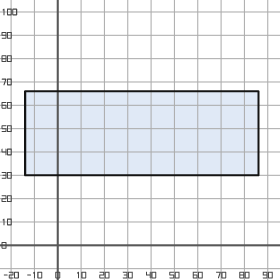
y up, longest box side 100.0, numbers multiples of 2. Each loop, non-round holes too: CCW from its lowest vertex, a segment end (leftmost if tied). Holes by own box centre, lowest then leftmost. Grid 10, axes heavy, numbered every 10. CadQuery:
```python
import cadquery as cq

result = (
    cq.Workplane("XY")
    .moveTo(-14.0, 30.0)
    .lineTo(86.0, 30.0)
    .lineTo(86.0, 66.0)
    .lineTo(-14.0, 66.0)
    .close()
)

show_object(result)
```